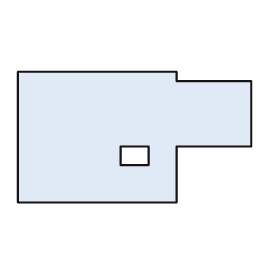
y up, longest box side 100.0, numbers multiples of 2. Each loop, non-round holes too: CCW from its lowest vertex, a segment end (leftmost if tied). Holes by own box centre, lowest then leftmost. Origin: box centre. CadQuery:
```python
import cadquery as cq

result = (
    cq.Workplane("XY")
    .moveTo(-50.0, -28.0)
    .lineTo(18.0, -28.0)
    .lineTo(18.0, -4.0)
    .lineTo(50.0, -4.0)
    .lineTo(50.0, 24.0)
    .lineTo(18.0, 24.0)
    .lineTo(18.0, 28.0)
    .lineTo(-50.0, 28.0)
    .close()
    .moveTo(-6.0, -12.0)
    .lineTo(6.0, -12.0)
    .lineTo(6.0, -4.0)
    .lineTo(-6.0, -4.0)
    .close()
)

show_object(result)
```